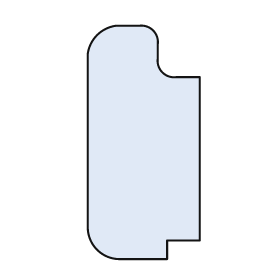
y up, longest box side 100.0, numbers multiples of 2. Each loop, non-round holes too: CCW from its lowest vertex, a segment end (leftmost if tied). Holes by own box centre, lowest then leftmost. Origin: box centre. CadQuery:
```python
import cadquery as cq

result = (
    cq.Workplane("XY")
    .moveTo(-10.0, -50.0)
    .lineTo(10.0, -50.0)
    .lineTo(10.0, -42.0)
    .lineTo(24.0, -42.0)
    .lineTo(24.0, 28.0)
    .lineTo(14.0, 28.0)
    .threePointArc((8.0, 30.0), (6.0, 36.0))
    .lineTo(6.0, 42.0)
    .threePointArc((4.0, 48.0), (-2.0, 50.0))
    .lineTo(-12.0, 50.0)
    .threePointArc((-20.0, 46.0), (-24.0, 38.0))
    .lineTo(-24.0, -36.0)
    .threePointArc((-20.0, -46.0), (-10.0, -50.0))
    .close()
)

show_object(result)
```